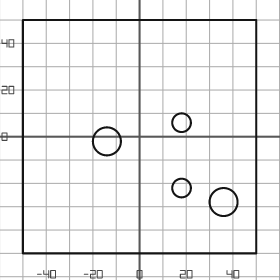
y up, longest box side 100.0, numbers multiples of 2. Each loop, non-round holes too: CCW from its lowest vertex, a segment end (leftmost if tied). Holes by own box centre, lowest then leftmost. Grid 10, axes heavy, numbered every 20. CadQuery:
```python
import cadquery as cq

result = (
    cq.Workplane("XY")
    .moveTo(-50.0, -50.0)
    .lineTo(50.0, -50.0)
    .lineTo(50.0, 50.0)
    .lineTo(-50.0, 50.0)
    .close()
    .moveTo(36.0, -28.0)
    .circle(6.0)
    .moveTo(18.0, -22.0)
    .circle(4.0)
    .moveTo(-14.0, -2.0)
    .circle(6.0)
    .moveTo(18.0, 6.0)
    .circle(4.0)
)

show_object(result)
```